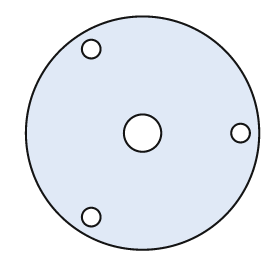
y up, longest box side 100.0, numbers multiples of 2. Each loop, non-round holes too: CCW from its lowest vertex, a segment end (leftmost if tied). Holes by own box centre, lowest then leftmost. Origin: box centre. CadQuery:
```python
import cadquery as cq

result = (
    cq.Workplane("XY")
    .moveTo(0.0, 0.0)
    .circle(50.0)
    .moveTo(-22.0, -36.0)
    .circle(4.0)
    .moveTo(0.0, 0.0)
    .circle(8.0)
    .moveTo(42.0, 0.0)
    .circle(4.0)
    .moveTo(-22.0, 36.0)
    .circle(4.0)
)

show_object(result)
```